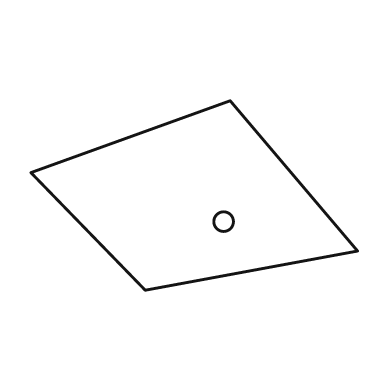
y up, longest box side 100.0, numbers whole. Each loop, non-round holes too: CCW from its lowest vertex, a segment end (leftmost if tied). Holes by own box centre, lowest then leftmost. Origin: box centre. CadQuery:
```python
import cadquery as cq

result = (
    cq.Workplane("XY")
    .moveTo(-15.0, -29.0)
    .lineTo(50.0, -17.0)
    .lineTo(11.0, 29.0)
    .lineTo(-50.0, 7.0)
    .close()
    .moveTo(9.0, -8.0)
    .circle(3.0)
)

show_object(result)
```